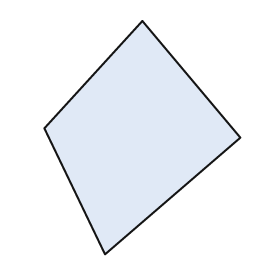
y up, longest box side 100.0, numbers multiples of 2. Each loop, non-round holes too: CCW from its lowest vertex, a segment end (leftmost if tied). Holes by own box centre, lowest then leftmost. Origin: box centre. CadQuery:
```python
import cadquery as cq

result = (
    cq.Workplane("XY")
    .moveTo(-16.0, -50.0)
    .lineTo(42.0, 0.0)
    .lineTo(0.0, 50.0)
    .lineTo(-42.0, 4.0)
    .close()
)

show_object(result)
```